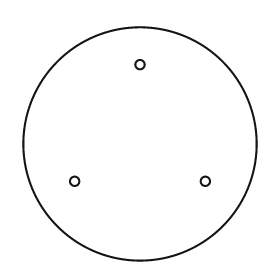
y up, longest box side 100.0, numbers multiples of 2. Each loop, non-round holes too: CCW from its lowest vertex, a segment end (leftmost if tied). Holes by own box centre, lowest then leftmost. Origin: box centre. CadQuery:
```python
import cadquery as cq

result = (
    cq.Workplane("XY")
    .moveTo(0.0, 0.0)
    .circle(50.0)
    .moveTo(-28.0, -16.0)
    .circle(2.0)
    .moveTo(28.0, -16.0)
    .circle(2.0)
    .moveTo(0.0, 34.0)
    .circle(2.0)
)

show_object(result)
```